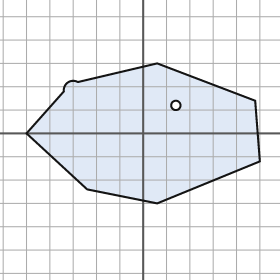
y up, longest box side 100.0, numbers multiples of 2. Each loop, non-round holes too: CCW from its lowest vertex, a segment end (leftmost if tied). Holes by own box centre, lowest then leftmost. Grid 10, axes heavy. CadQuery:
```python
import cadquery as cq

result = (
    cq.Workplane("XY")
    .moveTo(6.0, -30.0)
    .lineTo(50.0, -12.0)
    .lineTo(48.0, 14.0)
    .lineTo(6.0, 30.0)
    .lineTo(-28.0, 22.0)
    .threePointArc((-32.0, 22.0), (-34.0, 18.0))
    .lineTo(-50.0, 0.0)
    .lineTo(-24.0, -24.0)
    .close()
    .moveTo(14.0, 12.0)
    .circle(2.0)
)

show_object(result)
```